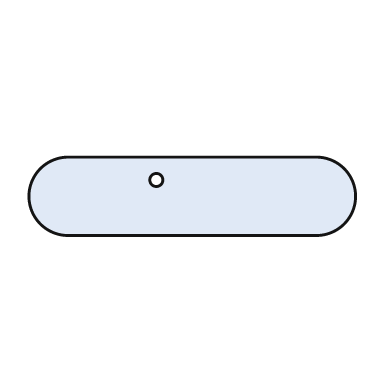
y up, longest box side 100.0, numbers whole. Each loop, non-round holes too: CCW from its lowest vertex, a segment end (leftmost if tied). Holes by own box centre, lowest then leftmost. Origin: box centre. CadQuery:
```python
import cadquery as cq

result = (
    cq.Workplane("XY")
    .moveTo(-38.0, -12.0)
    .lineTo(38.0, -12.0)
    .threePointArc((50.0, 0.0), (38.0, 12.0))
    .lineTo(-38.0, 12.0)
    .threePointArc((-50.0, 0.0), (-38.0, -12.0))
    .close()
    .moveTo(-11.0, 5.0)
    .circle(2.0)
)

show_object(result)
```